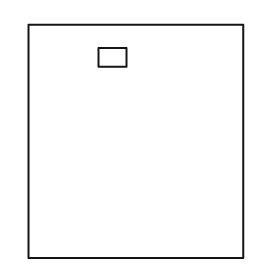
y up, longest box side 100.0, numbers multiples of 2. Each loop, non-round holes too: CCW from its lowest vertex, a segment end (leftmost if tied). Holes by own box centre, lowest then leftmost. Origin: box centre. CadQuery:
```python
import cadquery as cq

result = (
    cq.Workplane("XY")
    .moveTo(-46.0, -50.0)
    .lineTo(46.0, -50.0)
    .lineTo(46.0, 50.0)
    .lineTo(-46.0, 50.0)
    .close()
    .moveTo(-16.0, 32.0)
    .lineTo(-4.0, 32.0)
    .lineTo(-4.0, 40.0)
    .lineTo(-16.0, 40.0)
    .close()
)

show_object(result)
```